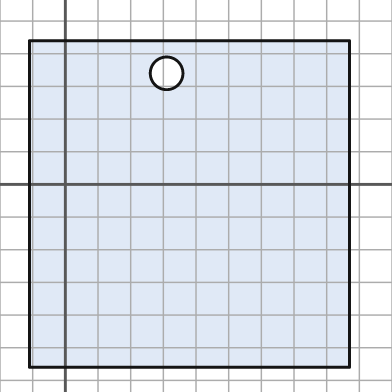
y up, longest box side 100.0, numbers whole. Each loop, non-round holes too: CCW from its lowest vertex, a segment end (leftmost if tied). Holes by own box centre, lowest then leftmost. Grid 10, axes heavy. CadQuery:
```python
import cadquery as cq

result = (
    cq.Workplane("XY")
    .moveTo(-11.0, -56.0)
    .lineTo(87.0, -56.0)
    .lineTo(87.0, 44.0)
    .lineTo(-11.0, 44.0)
    .close()
    .moveTo(31.0, 34.0)
    .circle(5.0)
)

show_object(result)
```